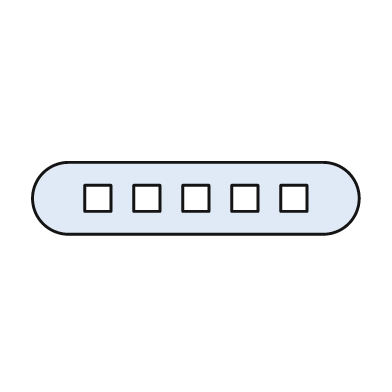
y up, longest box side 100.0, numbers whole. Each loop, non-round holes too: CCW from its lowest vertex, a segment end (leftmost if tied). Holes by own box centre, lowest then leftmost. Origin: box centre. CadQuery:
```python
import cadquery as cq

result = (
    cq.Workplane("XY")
    .moveTo(-39.0, -11.0)
    .lineTo(39.0, -11.0)
    .threePointArc((50.0, 0.0), (39.0, 11.0))
    .lineTo(-39.0, 11.0)
    .threePointArc((-50.0, 0.0), (-39.0, -11.0))
    .close()
    .moveTo(-34.0, -4.0)
    .lineTo(-26.0, -4.0)
    .lineTo(-26.0, 4.0)
    .lineTo(-34.0, 4.0)
    .close()
    .moveTo(-19.0, -4.0)
    .lineTo(-11.0, -4.0)
    .lineTo(-11.0, 4.0)
    .lineTo(-19.0, 4.0)
    .close()
    .moveTo(-4.0, -4.0)
    .lineTo(4.0, -4.0)
    .lineTo(4.0, 4.0)
    .lineTo(-4.0, 4.0)
    .close()
    .moveTo(11.0, -4.0)
    .lineTo(19.0, -4.0)
    .lineTo(19.0, 4.0)
    .lineTo(11.0, 4.0)
    .close()
    .moveTo(26.0, -4.0)
    .lineTo(34.0, -4.0)
    .lineTo(34.0, 4.0)
    .lineTo(26.0, 4.0)
    .close()
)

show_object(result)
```